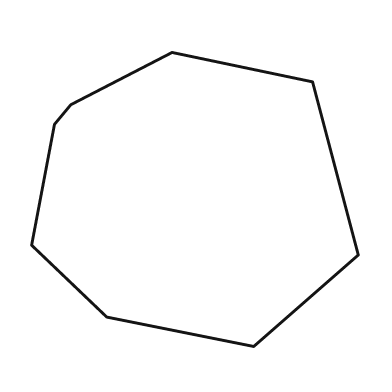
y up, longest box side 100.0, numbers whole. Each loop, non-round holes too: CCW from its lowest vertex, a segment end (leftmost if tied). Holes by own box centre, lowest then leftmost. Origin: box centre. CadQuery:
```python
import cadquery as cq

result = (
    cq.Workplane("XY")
    .moveTo(18.0, -45.0)
    .lineTo(50.0, -17.0)
    .lineTo(36.0, 36.0)
    .lineTo(-7.0, 45.0)
    .lineTo(-38.0, 29.0)
    .lineTo(-43.0, 23.0)
    .lineTo(-50.0, -14.0)
    .lineTo(-27.0, -36.0)
    .close()
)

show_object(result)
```